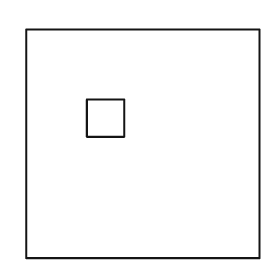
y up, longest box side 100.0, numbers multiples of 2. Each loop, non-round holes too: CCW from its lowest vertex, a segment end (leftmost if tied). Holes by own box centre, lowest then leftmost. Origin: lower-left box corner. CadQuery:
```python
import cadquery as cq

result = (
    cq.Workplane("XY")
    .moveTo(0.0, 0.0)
    .lineTo(100.0, 0.0)
    .lineTo(100.0, 98.0)
    .lineTo(0.0, 98.0)
    .close()
    .moveTo(26.0, 52.0)
    .lineTo(42.0, 52.0)
    .lineTo(42.0, 68.0)
    .lineTo(26.0, 68.0)
    .close()
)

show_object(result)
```